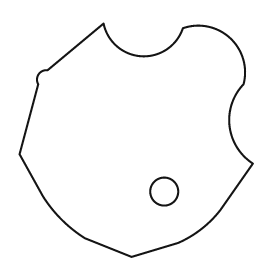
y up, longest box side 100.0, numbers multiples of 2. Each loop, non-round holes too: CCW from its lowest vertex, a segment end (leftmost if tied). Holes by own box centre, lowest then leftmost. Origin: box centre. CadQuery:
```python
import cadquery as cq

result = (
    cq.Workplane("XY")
    .moveTo(-2.0, -50.0)
    .lineTo(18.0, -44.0)
    .threePointArc((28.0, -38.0), (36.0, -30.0))
    .lineTo(50.0, -10.0)
    .threePointArc((40.0, 6.0), (46.0, 24.0))
    .threePointArc((40.0, 44.0), (20.0, 48.0))
    .threePointArc((2.0, 36.0), (-14.0, 50.0))
    .lineTo(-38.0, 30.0)
    .threePointArc((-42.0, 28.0), (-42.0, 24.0))
    .lineTo(-50.0, -6.0)
    .lineTo(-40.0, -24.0)
    .threePointArc((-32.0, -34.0), (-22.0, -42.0))
    .close()
    .moveTo(12.0, -22.0)
    .circle(6.0)
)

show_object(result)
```